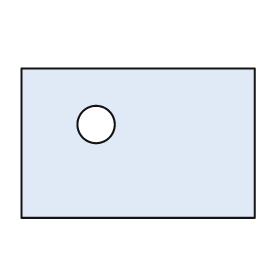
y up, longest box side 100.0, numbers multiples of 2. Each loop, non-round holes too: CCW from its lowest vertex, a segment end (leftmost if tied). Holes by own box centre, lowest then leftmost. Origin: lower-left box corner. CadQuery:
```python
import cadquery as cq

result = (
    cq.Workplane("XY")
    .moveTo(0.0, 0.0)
    .lineTo(100.0, 0.0)
    .lineTo(100.0, 64.0)
    .lineTo(0.0, 64.0)
    .close()
    .moveTo(32.0, 40.0)
    .circle(8.0)
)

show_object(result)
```